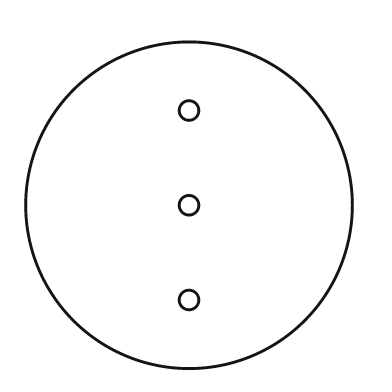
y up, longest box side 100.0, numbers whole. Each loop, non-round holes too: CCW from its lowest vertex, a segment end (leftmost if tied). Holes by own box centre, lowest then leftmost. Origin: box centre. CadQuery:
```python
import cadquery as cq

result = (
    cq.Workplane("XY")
    .moveTo(0.0, 0.0)
    .circle(50.0)
    .moveTo(0.0, -29.0)
    .circle(3.0)
    .moveTo(0.0, 0.0)
    .circle(3.0)
    .moveTo(0.0, 29.0)
    .circle(3.0)
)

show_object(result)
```